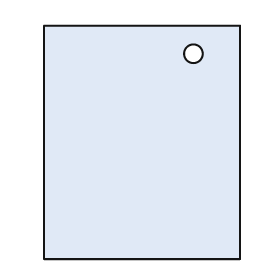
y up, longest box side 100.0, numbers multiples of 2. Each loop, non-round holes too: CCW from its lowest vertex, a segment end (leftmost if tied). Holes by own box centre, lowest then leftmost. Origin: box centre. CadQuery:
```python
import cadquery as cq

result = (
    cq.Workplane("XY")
    .moveTo(-42.0, -50.0)
    .lineTo(42.0, -50.0)
    .lineTo(42.0, 50.0)
    .lineTo(-42.0, 50.0)
    .close()
    .moveTo(22.0, 38.0)
    .circle(4.0)
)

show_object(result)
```